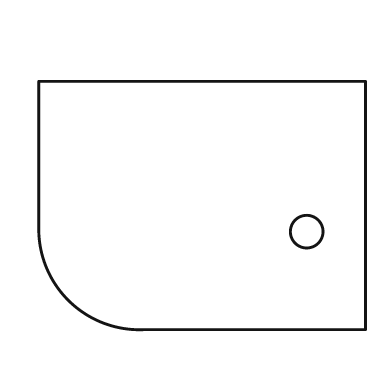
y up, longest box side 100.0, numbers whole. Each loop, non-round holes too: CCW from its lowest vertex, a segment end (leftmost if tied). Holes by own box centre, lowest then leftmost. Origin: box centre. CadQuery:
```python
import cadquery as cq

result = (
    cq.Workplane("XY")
    .moveTo(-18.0, -38.0)
    .lineTo(50.0, -38.0)
    .lineTo(50.0, 38.0)
    .lineTo(-50.0, 38.0)
    .lineTo(-50.0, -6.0)
    .threePointArc((-41.0, -29.0), (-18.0, -38.0))
    .close()
    .moveTo(32.0, -8.0)
    .circle(5.0)
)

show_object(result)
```